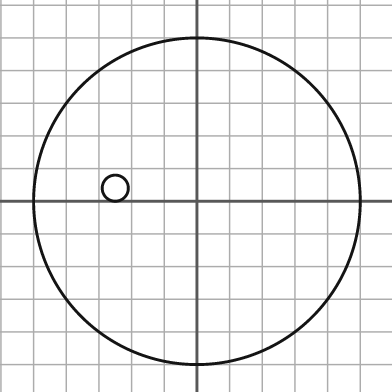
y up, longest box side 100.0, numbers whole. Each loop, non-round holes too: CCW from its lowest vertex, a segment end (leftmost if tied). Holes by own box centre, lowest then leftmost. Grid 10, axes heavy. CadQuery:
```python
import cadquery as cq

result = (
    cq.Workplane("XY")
    .moveTo(0.0, 0.0)
    .circle(50.0)
    .moveTo(-25.0, 4.0)
    .circle(4.0)
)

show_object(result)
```